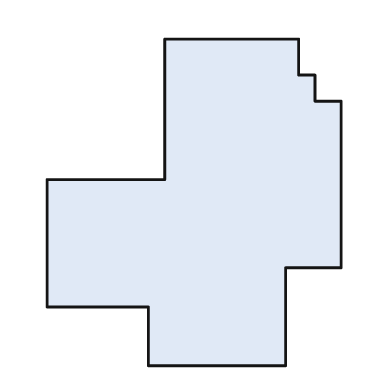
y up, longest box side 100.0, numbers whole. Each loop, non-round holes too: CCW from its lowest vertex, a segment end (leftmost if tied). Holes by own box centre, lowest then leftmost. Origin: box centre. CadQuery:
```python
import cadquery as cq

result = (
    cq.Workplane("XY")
    .moveTo(-14.0, -50.0)
    .lineTo(28.0, -50.0)
    .lineTo(28.0, -20.0)
    .lineTo(45.0, -20.0)
    .lineTo(45.0, 31.0)
    .lineTo(37.0, 31.0)
    .lineTo(37.0, 39.0)
    .lineTo(32.0, 39.0)
    .lineTo(32.0, 50.0)
    .lineTo(-9.0, 50.0)
    .lineTo(-9.0, 7.0)
    .lineTo(-45.0, 7.0)
    .lineTo(-45.0, -32.0)
    .lineTo(-14.0, -32.0)
    .close()
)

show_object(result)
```